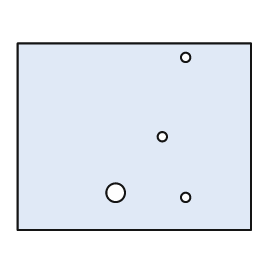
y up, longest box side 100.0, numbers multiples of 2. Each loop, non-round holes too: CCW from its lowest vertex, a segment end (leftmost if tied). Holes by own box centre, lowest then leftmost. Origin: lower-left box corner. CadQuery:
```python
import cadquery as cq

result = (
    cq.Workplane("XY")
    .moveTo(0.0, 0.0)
    .lineTo(100.0, 0.0)
    .lineTo(100.0, 80.0)
    .lineTo(0.0, 80.0)
    .close()
    .moveTo(72.0, 14.0)
    .circle(2.0)
    .moveTo(42.0, 16.0)
    .circle(4.0)
    .moveTo(62.0, 40.0)
    .circle(2.0)
    .moveTo(72.0, 74.0)
    .circle(2.0)
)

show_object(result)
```